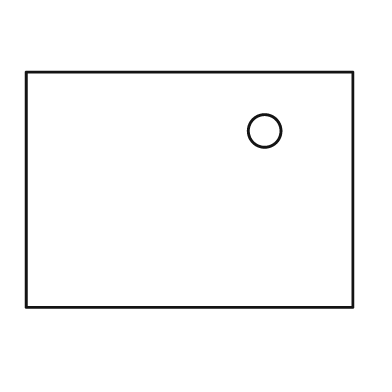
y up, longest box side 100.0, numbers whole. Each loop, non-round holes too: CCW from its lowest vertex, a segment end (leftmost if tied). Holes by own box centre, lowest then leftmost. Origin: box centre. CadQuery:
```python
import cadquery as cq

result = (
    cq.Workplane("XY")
    .moveTo(-50.0, -36.0)
    .lineTo(50.0, -36.0)
    .lineTo(50.0, 36.0)
    .lineTo(-50.0, 36.0)
    .close()
    .moveTo(23.0, 18.0)
    .circle(5.0)
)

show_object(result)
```